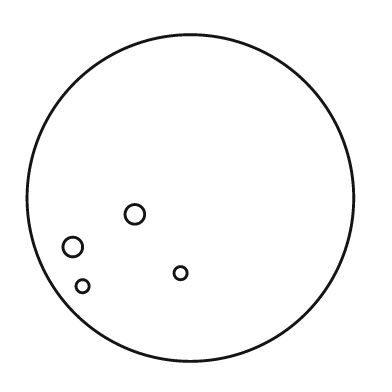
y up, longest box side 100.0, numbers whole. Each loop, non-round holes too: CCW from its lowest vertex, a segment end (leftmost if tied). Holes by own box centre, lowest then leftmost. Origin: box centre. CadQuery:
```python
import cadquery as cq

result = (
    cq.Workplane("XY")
    .moveTo(0.0, 0.0)
    .circle(50.0)
    .moveTo(-33.0, -27.0)
    .circle(2.0)
    .moveTo(-3.0, -23.0)
    .circle(2.0)
    .moveTo(-36.0, -15.0)
    .circle(3.0)
    .moveTo(-17.0, -5.0)
    .circle(3.0)
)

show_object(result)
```